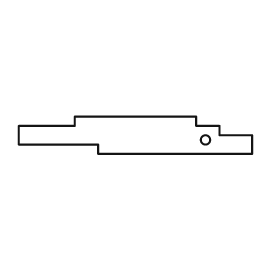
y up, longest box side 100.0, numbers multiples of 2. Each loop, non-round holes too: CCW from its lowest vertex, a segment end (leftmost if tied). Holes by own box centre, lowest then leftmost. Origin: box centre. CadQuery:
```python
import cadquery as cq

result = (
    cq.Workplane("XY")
    .moveTo(-16.0, -8.0)
    .lineTo(50.0, -8.0)
    .lineTo(50.0, 0.0)
    .lineTo(36.0, 0.0)
    .lineTo(36.0, 4.0)
    .lineTo(26.0, 4.0)
    .lineTo(26.0, 8.0)
    .lineTo(-26.0, 8.0)
    .lineTo(-26.0, 4.0)
    .lineTo(-50.0, 4.0)
    .lineTo(-50.0, -4.0)
    .lineTo(-16.0, -4.0)
    .close()
    .moveTo(30.0, -2.0)
    .circle(2.0)
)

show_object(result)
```